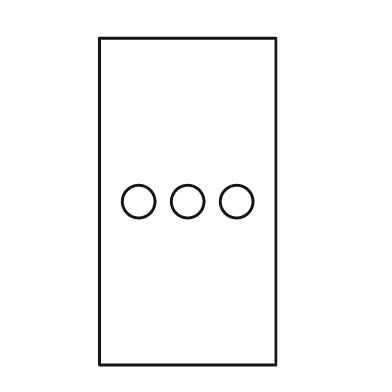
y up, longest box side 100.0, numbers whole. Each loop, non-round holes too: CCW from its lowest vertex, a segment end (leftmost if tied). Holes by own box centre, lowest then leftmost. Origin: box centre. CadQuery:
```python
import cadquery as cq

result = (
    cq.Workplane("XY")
    .moveTo(-27.0, -50.0)
    .lineTo(27.0, -50.0)
    .lineTo(27.0, 50.0)
    .lineTo(-27.0, 50.0)
    .close()
    .moveTo(-15.0, 0.0)
    .circle(5.0)
    .moveTo(0.0, 0.0)
    .circle(5.0)
    .moveTo(15.0, 0.0)
    .circle(5.0)
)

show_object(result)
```